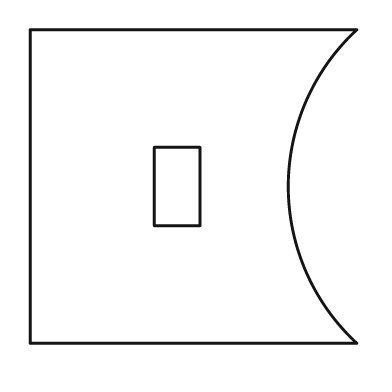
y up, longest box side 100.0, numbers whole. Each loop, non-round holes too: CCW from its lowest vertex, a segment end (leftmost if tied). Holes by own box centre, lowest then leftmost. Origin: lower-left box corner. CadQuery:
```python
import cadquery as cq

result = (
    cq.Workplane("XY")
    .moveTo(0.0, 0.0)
    .lineTo(100.0, 0.0)
    .threePointArc((79.0, 48.0), (100.0, 96.0))
    .lineTo(0.0, 96.0)
    .close()
    .moveTo(38.0, 36.0)
    .lineTo(52.0, 36.0)
    .lineTo(52.0, 60.0)
    .lineTo(38.0, 60.0)
    .close()
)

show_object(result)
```